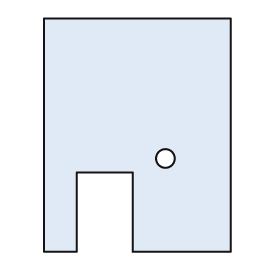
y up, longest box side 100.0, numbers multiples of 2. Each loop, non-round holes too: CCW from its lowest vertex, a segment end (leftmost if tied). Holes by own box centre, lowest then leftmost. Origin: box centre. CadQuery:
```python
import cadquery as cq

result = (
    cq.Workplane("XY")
    .moveTo(-40.0, -50.0)
    .lineTo(-26.0, -50.0)
    .lineTo(-26.0, -16.0)
    .lineTo(-2.0, -16.0)
    .lineTo(-2.0, -50.0)
    .lineTo(40.0, -50.0)
    .lineTo(40.0, 50.0)
    .lineTo(-40.0, 50.0)
    .close()
    .moveTo(12.0, -10.0)
    .circle(4.0)
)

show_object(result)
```